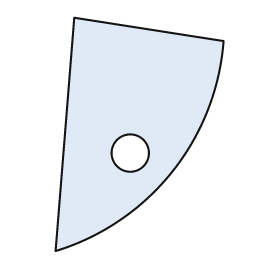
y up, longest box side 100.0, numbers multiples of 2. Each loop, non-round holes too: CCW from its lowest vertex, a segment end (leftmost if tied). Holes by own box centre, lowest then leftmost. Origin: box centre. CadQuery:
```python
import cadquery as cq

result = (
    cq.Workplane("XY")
    .moveTo(-36.0, -50.0)
    .threePointArc((14.0, -16.0), (36.0, 40.0))
    .lineTo(-28.0, 50.0)
    .close()
    .moveTo(-4.0, -8.0)
    .circle(8.0)
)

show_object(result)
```